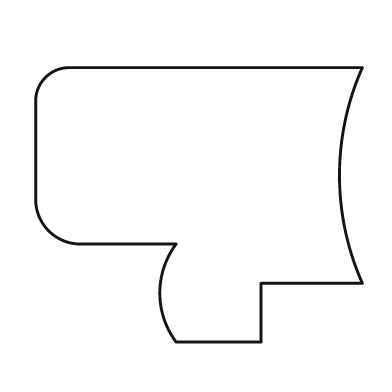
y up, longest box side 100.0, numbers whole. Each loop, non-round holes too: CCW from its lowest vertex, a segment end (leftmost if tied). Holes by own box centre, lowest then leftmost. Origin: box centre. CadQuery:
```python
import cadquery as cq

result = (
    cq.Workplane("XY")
    .moveTo(-7.0, -42.0)
    .lineTo(19.0, -42.0)
    .lineTo(19.0, -24.0)
    .lineTo(50.0, -24.0)
    .threePointArc((43.0, 9.0), (50.0, 42.0))
    .lineTo(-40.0, 42.0)
    .threePointArc((-47.0, 39.0), (-50.0, 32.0))
    .lineTo(-50.0, 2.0)
    .threePointArc((-46.0, -8.0), (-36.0, -12.0))
    .lineTo(-7.0, -12.0)
    .threePointArc((-12.0, -27.0), (-7.0, -42.0))
    .close()
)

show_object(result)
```